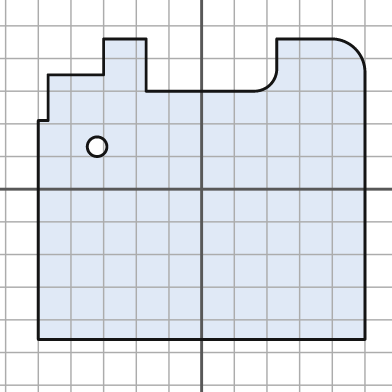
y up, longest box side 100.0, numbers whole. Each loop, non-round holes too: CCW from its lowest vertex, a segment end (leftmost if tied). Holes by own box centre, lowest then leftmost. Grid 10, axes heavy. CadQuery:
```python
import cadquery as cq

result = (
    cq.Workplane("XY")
    .moveTo(-50.0, -46.0)
    .lineTo(50.0, -46.0)
    .lineTo(50.0, 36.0)
    .threePointArc((47.0, 43.0), (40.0, 46.0))
    .lineTo(23.0, 46.0)
    .lineTo(23.0, 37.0)
    .threePointArc((21.0, 32.0), (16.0, 30.0))
    .lineTo(-17.0, 30.0)
    .lineTo(-17.0, 46.0)
    .lineTo(-30.0, 46.0)
    .lineTo(-30.0, 35.0)
    .lineTo(-47.0, 35.0)
    .lineTo(-47.0, 21.0)
    .lineTo(-50.0, 21.0)
    .close()
    .moveTo(-32.0, 13.0)
    .circle(3.0)
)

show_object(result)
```